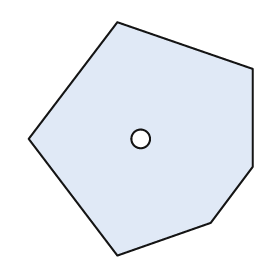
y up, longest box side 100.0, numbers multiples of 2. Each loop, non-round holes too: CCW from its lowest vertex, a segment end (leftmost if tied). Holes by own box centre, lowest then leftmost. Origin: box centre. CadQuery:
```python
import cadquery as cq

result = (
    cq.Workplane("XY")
    .moveTo(-10.0, -50.0)
    .lineTo(30.0, -36.0)
    .lineTo(48.0, -12.0)
    .lineTo(48.0, 30.0)
    .lineTo(-10.0, 50.0)
    .lineTo(-48.0, 0.0)
    .close()
    .moveTo(0.0, 0.0)
    .circle(4.0)
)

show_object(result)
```